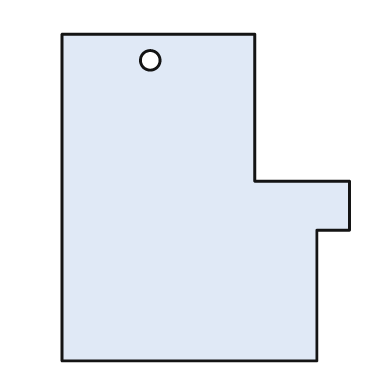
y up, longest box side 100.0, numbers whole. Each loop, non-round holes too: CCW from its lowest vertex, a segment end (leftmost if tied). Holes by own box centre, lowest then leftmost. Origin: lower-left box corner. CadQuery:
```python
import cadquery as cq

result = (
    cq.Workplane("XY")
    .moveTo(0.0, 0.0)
    .lineTo(78.0, 0.0)
    .lineTo(78.0, 40.0)
    .lineTo(88.0, 40.0)
    .lineTo(88.0, 55.0)
    .lineTo(59.0, 55.0)
    .lineTo(59.0, 100.0)
    .lineTo(0.0, 100.0)
    .close()
    .moveTo(27.0, 92.0)
    .circle(3.0)
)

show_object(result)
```